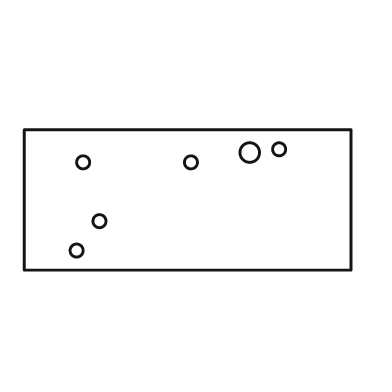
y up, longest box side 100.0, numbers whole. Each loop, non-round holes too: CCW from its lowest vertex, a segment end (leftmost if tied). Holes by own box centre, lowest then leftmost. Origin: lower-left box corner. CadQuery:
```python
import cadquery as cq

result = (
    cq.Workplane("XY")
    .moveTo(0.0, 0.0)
    .lineTo(100.0, 0.0)
    .lineTo(100.0, 43.0)
    .lineTo(0.0, 43.0)
    .close()
    .moveTo(16.0, 6.0)
    .circle(2.0)
    .moveTo(23.0, 15.0)
    .circle(2.0)
    .moveTo(18.0, 33.0)
    .circle(2.0)
    .moveTo(51.0, 33.0)
    .circle(2.0)
    .moveTo(69.0, 36.0)
    .circle(3.0)
    .moveTo(78.0, 37.0)
    .circle(2.0)
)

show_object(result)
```